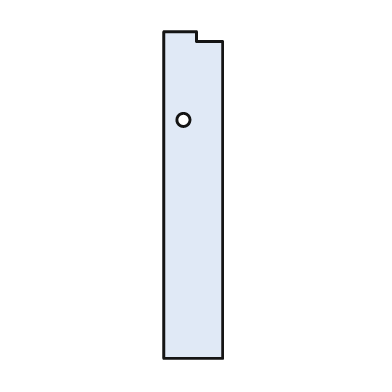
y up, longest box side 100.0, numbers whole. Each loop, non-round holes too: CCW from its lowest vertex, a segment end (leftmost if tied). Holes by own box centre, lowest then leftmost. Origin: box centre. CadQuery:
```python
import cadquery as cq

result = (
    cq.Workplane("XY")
    .moveTo(-9.0, -50.0)
    .lineTo(9.0, -50.0)
    .lineTo(9.0, 47.0)
    .lineTo(1.0, 47.0)
    .lineTo(1.0, 50.0)
    .lineTo(-9.0, 50.0)
    .close()
    .moveTo(-3.0, 23.0)
    .circle(2.0)
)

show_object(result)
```